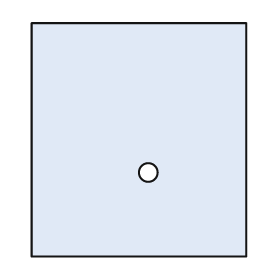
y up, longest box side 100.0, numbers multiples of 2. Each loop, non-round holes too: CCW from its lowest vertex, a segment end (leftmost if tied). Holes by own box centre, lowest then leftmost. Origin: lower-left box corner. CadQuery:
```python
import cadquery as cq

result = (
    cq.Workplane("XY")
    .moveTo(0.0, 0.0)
    .lineTo(92.0, 0.0)
    .lineTo(92.0, 100.0)
    .lineTo(0.0, 100.0)
    .close()
    .moveTo(50.0, 36.0)
    .circle(4.0)
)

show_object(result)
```